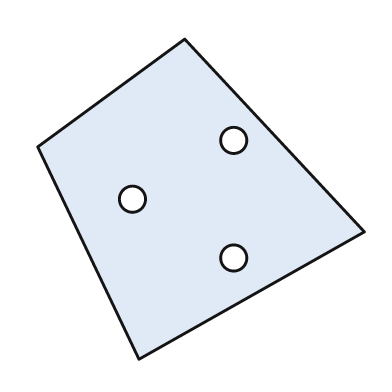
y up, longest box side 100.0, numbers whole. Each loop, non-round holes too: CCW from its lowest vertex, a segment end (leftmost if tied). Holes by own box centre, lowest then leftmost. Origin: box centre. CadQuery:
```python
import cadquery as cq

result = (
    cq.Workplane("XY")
    .moveTo(-19.0, -49.0)
    .lineTo(50.0, -10.0)
    .lineTo(-5.0, 49.0)
    .lineTo(-50.0, 16.0)
    .close()
    .moveTo(10.0, -18.0)
    .circle(4.0)
    .moveTo(-21.0, 0.0)
    .circle(4.0)
    .moveTo(10.0, 18.0)
    .circle(4.0)
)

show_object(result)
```